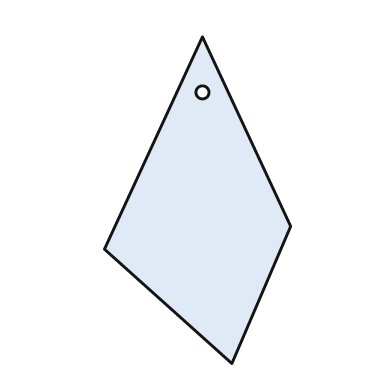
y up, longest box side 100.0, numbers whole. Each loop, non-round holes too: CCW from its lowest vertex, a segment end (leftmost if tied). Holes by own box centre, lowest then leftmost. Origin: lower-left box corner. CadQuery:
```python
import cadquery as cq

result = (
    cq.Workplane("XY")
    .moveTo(39.0, 0.0)
    .lineTo(57.0, 42.0)
    .lineTo(30.0, 100.0)
    .lineTo(0.0, 35.0)
    .close()
    .moveTo(30.0, 83.0)
    .circle(2.0)
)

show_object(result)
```